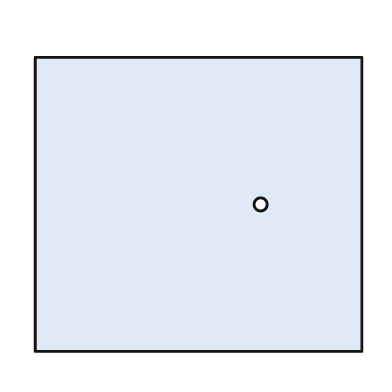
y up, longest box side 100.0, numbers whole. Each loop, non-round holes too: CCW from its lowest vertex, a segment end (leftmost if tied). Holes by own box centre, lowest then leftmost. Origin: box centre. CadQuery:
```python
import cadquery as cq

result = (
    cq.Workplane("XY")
    .moveTo(-50.0, -45.0)
    .lineTo(50.0, -45.0)
    .lineTo(50.0, 45.0)
    .lineTo(-50.0, 45.0)
    .close()
    .moveTo(19.0, 0.0)
    .circle(2.0)
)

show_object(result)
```